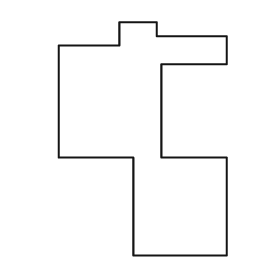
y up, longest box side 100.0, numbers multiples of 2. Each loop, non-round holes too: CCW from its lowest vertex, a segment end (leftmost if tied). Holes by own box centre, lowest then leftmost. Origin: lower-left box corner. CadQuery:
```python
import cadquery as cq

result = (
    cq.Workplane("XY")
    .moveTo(32.0, 0.0)
    .lineTo(72.0, 0.0)
    .lineTo(72.0, 42.0)
    .lineTo(44.0, 42.0)
    .lineTo(44.0, 82.0)
    .lineTo(72.0, 82.0)
    .lineTo(72.0, 94.0)
    .lineTo(42.0, 94.0)
    .lineTo(42.0, 100.0)
    .lineTo(26.0, 100.0)
    .lineTo(26.0, 90.0)
    .lineTo(0.0, 90.0)
    .lineTo(0.0, 42.0)
    .lineTo(32.0, 42.0)
    .close()
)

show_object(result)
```